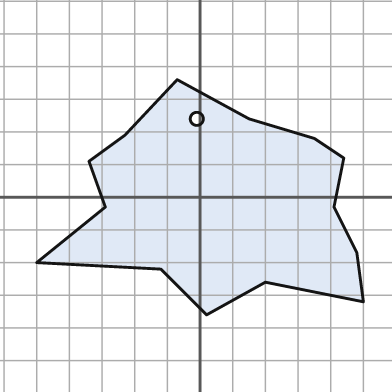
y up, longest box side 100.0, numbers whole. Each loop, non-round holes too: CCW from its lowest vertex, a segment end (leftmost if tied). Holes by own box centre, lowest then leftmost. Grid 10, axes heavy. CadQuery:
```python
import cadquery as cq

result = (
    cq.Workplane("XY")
    .moveTo(2.0, -36.0)
    .lineTo(20.0, -26.0)
    .lineTo(50.0, -32.0)
    .lineTo(48.0, -17.0)
    .lineTo(41.0, -3.0)
    .lineTo(44.0, 12.0)
    .lineTo(35.0, 18.0)
    .lineTo(15.0, 24.0)
    .lineTo(-7.0, 36.0)
    .lineTo(-23.0, 19.0)
    .lineTo(-34.0, 11.0)
    .lineTo(-29.0, -3.0)
    .lineTo(-50.0, -20.0)
    .lineTo(-12.0, -22.0)
    .close()
    .moveTo(-1.0, 24.0)
    .circle(2.0)
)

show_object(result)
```